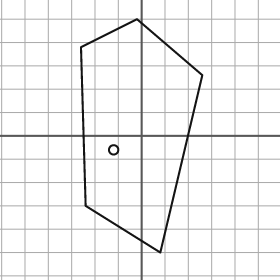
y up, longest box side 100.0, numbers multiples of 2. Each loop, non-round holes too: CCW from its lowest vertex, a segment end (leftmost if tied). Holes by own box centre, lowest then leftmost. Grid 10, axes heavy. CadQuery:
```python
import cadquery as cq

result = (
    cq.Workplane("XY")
    .moveTo(8.0, -50.0)
    .lineTo(26.0, 26.0)
    .lineTo(-2.0, 50.0)
    .lineTo(-26.0, 38.0)
    .lineTo(-24.0, -30.0)
    .close()
    .moveTo(-12.0, -6.0)
    .circle(2.0)
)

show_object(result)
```